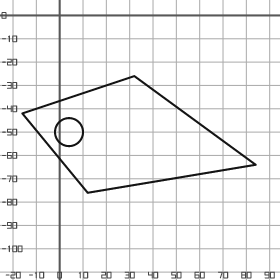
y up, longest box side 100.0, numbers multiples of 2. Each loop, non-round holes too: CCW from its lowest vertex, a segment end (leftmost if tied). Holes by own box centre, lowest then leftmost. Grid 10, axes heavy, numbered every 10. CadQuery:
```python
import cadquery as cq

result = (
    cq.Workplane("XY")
    .moveTo(12.0, -76.0)
    .lineTo(84.0, -64.0)
    .lineTo(32.0, -26.0)
    .lineTo(-16.0, -42.0)
    .close()
    .moveTo(4.0, -50.0)
    .circle(6.0)
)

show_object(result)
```